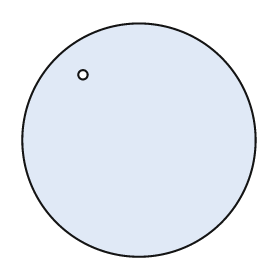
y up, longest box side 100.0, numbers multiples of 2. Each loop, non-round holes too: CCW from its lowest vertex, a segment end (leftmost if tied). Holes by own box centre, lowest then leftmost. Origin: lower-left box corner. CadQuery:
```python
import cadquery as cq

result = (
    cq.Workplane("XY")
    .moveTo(50.0, 50.0)
    .circle(50.0)
    .moveTo(26.0, 78.0)
    .circle(2.0)
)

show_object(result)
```